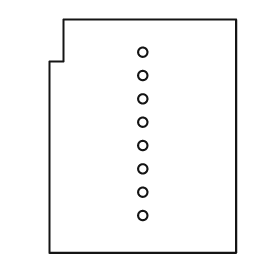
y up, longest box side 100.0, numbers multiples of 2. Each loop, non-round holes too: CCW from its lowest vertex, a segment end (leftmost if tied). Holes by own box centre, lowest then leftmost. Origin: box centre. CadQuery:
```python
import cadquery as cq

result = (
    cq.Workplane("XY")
    .moveTo(-40.0, -50.0)
    .lineTo(40.0, -50.0)
    .lineTo(40.0, 50.0)
    .lineTo(-34.0, 50.0)
    .lineTo(-34.0, 32.0)
    .lineTo(-40.0, 32.0)
    .close()
    .moveTo(0.0, -34.0)
    .circle(2.0)
    .moveTo(0.0, -24.0)
    .circle(2.0)
    .moveTo(0.0, -14.0)
    .circle(2.0)
    .moveTo(0.0, -4.0)
    .circle(2.0)
    .moveTo(0.0, 6.0)
    .circle(2.0)
    .moveTo(0.0, 16.0)
    .circle(2.0)
    .moveTo(0.0, 26.0)
    .circle(2.0)
    .moveTo(0.0, 36.0)
    .circle(2.0)
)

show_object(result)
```